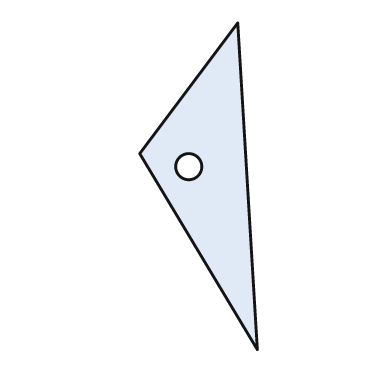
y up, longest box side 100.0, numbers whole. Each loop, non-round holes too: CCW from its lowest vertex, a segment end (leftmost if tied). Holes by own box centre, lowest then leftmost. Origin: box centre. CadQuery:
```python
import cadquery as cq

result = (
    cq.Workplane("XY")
    .moveTo(18.0, -50.0)
    .lineTo(12.0, 50.0)
    .lineTo(-18.0, 10.0)
    .close()
    .moveTo(-3.0, 6.0)
    .circle(4.0)
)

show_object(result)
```